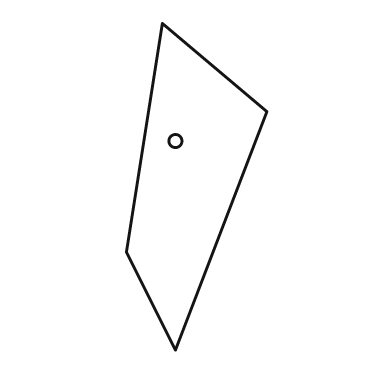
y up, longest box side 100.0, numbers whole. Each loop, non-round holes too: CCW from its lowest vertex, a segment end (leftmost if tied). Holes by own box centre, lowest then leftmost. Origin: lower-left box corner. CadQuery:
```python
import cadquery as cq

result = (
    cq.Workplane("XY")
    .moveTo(15.0, 0.0)
    .lineTo(43.0, 73.0)
    .lineTo(11.0, 100.0)
    .lineTo(0.0, 30.0)
    .close()
    .moveTo(15.0, 64.0)
    .circle(2.0)
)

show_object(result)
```